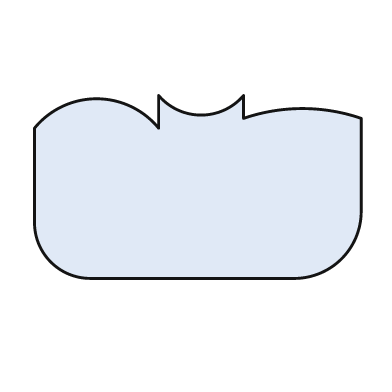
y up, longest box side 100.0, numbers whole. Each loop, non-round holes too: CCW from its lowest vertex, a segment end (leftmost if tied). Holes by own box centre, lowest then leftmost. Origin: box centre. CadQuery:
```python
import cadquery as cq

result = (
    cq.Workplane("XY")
    .moveTo(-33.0, -28.0)
    .lineTo(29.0, -28.0)
    .threePointArc((44.0, -22.0), (50.0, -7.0))
    .lineTo(50.0, 21.0)
    .threePointArc((32.0, 24.0), (14.0, 21.0))
    .lineTo(14.0, 28.0)
    .threePointArc((1.0, 22.0), (-12.0, 28.0))
    .lineTo(-12.0, 18.0)
    .threePointArc((-31.0, 27.0), (-50.0, 18.0))
    .lineTo(-50.0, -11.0)
    .threePointArc((-45.0, -23.0), (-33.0, -28.0))
    .close()
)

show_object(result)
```